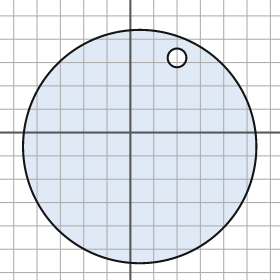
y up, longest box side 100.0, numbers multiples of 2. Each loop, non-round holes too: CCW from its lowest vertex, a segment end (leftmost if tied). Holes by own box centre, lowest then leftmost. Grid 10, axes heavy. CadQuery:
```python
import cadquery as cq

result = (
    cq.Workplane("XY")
    .moveTo(4.0, -6.0)
    .circle(50.0)
    .moveTo(20.0, 32.0)
    .circle(4.0)
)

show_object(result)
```